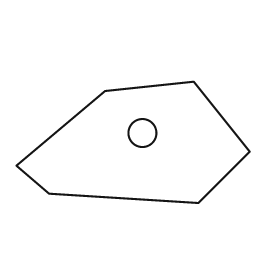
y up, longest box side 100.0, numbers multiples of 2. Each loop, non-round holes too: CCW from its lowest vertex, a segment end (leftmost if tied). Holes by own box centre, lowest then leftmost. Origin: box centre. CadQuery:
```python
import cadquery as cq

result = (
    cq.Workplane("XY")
    .moveTo(28.0, -26.0)
    .lineTo(50.0, -4.0)
    .lineTo(26.0, 26.0)
    .lineTo(-12.0, 22.0)
    .lineTo(-50.0, -10.0)
    .lineTo(-36.0, -22.0)
    .close()
    .moveTo(4.0, 4.0)
    .circle(6.0)
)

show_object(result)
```